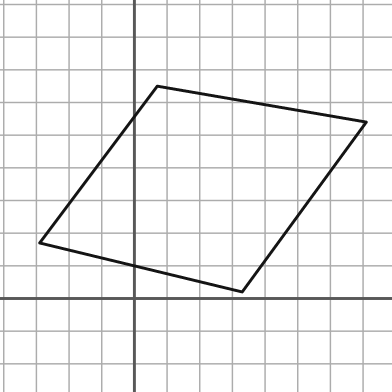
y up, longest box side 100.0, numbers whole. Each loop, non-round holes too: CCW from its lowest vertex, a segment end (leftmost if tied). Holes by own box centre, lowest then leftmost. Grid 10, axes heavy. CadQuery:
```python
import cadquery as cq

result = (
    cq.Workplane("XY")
    .moveTo(33.0, 2.0)
    .lineTo(71.0, 54.0)
    .lineTo(7.0, 65.0)
    .lineTo(-29.0, 17.0)
    .close()
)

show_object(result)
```